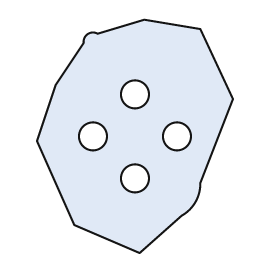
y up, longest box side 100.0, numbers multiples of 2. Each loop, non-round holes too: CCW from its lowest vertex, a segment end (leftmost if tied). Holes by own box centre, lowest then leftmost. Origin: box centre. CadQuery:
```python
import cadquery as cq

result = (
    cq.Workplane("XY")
    .moveTo(2.0, -50.0)
    .lineTo(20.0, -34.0)
    .threePointArc((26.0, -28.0), (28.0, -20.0))
    .lineTo(42.0, 16.0)
    .lineTo(28.0, 46.0)
    .lineTo(4.0, 50.0)
    .lineTo(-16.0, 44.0)
    .threePointArc((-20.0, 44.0), (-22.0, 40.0))
    .lineTo(-34.0, 22.0)
    .lineTo(-42.0, -2.0)
    .lineTo(-26.0, -38.0)
    .close()
    .moveTo(0.0, -18.0)
    .circle(6.0)
    .moveTo(-18.0, 0.0)
    .circle(6.0)
    .moveTo(18.0, 0.0)
    .circle(6.0)
    .moveTo(0.0, 18.0)
    .circle(6.0)
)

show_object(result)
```